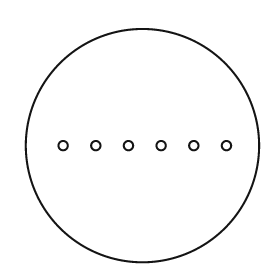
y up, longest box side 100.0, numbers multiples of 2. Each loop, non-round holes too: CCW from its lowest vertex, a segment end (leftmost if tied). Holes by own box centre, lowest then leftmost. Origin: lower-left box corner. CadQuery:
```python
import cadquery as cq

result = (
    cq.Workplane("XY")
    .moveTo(50.0, 50.0)
    .circle(50.0)
    .moveTo(16.0, 50.0)
    .circle(2.0)
    .moveTo(30.0, 50.0)
    .circle(2.0)
    .moveTo(44.0, 50.0)
    .circle(2.0)
    .moveTo(58.0, 50.0)
    .circle(2.0)
    .moveTo(72.0, 50.0)
    .circle(2.0)
    .moveTo(86.0, 50.0)
    .circle(2.0)
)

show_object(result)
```